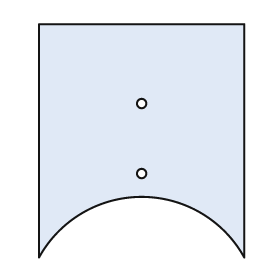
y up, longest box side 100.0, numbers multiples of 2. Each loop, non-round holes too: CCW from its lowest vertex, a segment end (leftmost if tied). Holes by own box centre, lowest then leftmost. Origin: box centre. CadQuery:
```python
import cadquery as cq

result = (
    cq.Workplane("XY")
    .moveTo(-44.0, -50.0)
    .threePointArc((0.0, -24.0), (44.0, -50.0))
    .lineTo(44.0, 50.0)
    .lineTo(-44.0, 50.0)
    .close()
    .moveTo(0.0, -14.0)
    .circle(2.0)
    .moveTo(0.0, 16.0)
    .circle(2.0)
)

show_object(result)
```